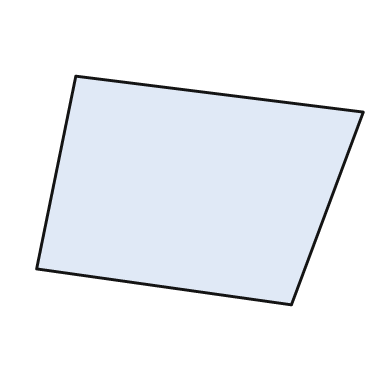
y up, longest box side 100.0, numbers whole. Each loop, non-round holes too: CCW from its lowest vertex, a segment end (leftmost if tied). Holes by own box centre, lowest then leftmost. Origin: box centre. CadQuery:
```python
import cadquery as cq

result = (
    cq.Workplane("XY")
    .moveTo(28.0, -35.0)
    .lineTo(50.0, 24.0)
    .lineTo(-38.0, 35.0)
    .lineTo(-50.0, -24.0)
    .close()
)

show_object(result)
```